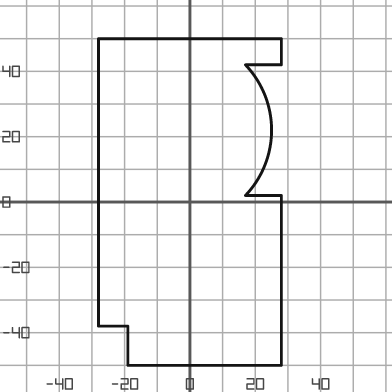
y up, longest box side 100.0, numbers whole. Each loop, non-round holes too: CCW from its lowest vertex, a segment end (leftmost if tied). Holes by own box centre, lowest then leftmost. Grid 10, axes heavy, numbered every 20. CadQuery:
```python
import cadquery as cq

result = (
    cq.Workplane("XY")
    .moveTo(-19.0, -50.0)
    .lineTo(28.0, -50.0)
    .lineTo(28.0, 2.0)
    .lineTo(17.0, 2.0)
    .threePointArc((25.0, 22.0), (17.0, 42.0))
    .lineTo(28.0, 42.0)
    .lineTo(28.0, 50.0)
    .lineTo(-28.0, 50.0)
    .lineTo(-28.0, -38.0)
    .lineTo(-19.0, -38.0)
    .close()
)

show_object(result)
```